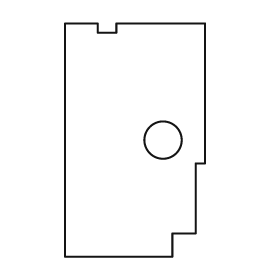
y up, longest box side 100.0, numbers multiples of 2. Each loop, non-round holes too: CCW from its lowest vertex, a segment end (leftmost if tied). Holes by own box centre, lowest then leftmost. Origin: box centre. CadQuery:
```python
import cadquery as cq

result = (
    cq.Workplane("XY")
    .moveTo(-30.0, -50.0)
    .lineTo(16.0, -50.0)
    .lineTo(16.0, -40.0)
    .lineTo(26.0, -40.0)
    .lineTo(26.0, -10.0)
    .lineTo(30.0, -10.0)
    .lineTo(30.0, 50.0)
    .lineTo(-8.0, 50.0)
    .lineTo(-8.0, 46.0)
    .lineTo(-16.0, 46.0)
    .lineTo(-16.0, 50.0)
    .lineTo(-30.0, 50.0)
    .close()
    .moveTo(12.0, 0.0)
    .circle(8.0)
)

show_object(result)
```